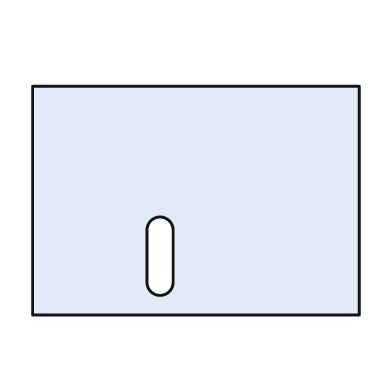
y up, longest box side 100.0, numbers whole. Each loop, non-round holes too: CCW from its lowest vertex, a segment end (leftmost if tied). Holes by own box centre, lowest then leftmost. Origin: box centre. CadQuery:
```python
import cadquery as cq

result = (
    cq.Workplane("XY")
    .moveTo(-50.0, -35.0)
    .lineTo(50.0, -35.0)
    .lineTo(50.0, 35.0)
    .lineTo(-50.0, 35.0)
    .close()
    .moveTo(-15.0, -25.0)
    .threePointArc((-11.0, -29.0), (-7.0, -25.0))
    .lineTo(-7.0, -9.0)
    .threePointArc((-11.0, -5.0), (-15.0, -9.0))
    .close()
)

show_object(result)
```